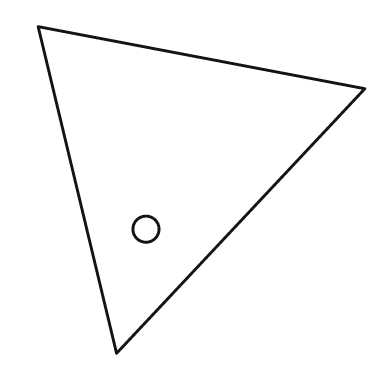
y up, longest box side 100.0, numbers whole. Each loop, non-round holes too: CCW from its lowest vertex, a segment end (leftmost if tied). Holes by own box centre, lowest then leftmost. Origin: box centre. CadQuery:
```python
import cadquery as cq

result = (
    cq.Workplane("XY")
    .moveTo(-26.0, -50.0)
    .lineTo(50.0, 31.0)
    .lineTo(-50.0, 50.0)
    .close()
    .moveTo(-17.0, -12.0)
    .circle(4.0)
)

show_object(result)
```